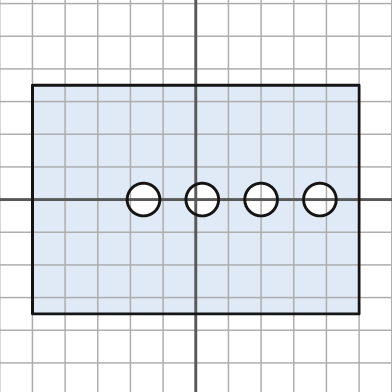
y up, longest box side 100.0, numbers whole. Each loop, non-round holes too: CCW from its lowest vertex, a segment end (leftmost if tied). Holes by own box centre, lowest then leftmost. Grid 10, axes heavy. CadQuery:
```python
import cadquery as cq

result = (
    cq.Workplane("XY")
    .moveTo(-50.0, -35.0)
    .lineTo(50.0, -35.0)
    .lineTo(50.0, 35.0)
    .lineTo(-50.0, 35.0)
    .close()
    .moveTo(-16.0, 0.0)
    .circle(5.0)
    .moveTo(2.0, 0.0)
    .circle(5.0)
    .moveTo(20.0, 0.0)
    .circle(5.0)
    .moveTo(38.0, 0.0)
    .circle(5.0)
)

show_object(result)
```